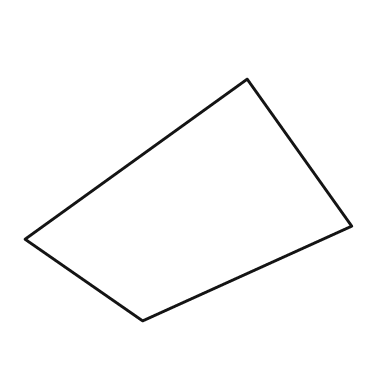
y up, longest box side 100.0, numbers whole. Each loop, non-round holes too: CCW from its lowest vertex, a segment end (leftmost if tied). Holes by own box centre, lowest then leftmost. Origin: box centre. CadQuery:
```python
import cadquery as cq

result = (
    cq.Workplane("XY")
    .moveTo(-14.0, -37.0)
    .lineTo(50.0, -8.0)
    .lineTo(18.0, 37.0)
    .lineTo(-50.0, -12.0)
    .close()
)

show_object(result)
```